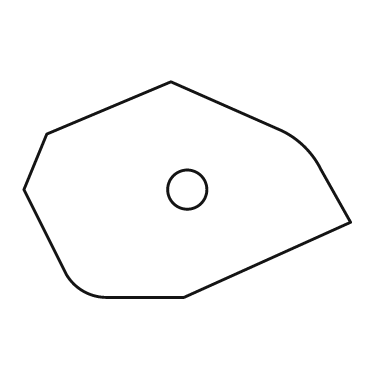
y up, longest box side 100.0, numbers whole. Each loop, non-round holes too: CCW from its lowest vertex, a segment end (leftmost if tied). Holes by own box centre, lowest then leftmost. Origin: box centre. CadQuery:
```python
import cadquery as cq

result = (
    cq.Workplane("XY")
    .moveTo(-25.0, -33.0)
    .lineTo(-1.0, -33.0)
    .lineTo(50.0, -10.0)
    .lineTo(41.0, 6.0)
    .threePointArc((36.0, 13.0), (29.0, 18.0))
    .lineTo(-5.0, 33.0)
    .lineTo(-43.0, 17.0)
    .lineTo(-50.0, 0.0)
    .lineTo(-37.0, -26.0)
    .threePointArc((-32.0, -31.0), (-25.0, -33.0))
    .close()
    .moveTo(0.0, 0.0)
    .circle(6.0)
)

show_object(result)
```